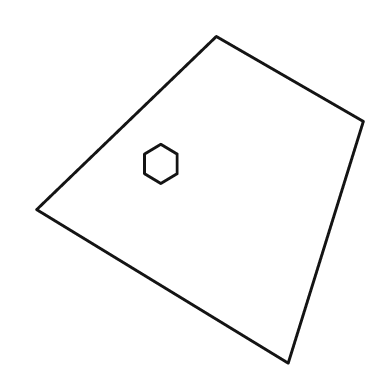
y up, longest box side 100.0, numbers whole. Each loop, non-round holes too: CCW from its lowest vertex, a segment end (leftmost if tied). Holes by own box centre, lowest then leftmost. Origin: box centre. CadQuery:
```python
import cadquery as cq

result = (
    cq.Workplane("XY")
    .moveTo(27.0, -50.0)
    .lineTo(50.0, 24.0)
    .lineTo(5.0, 50.0)
    .lineTo(-50.0, -3.0)
    .close()
    .moveTo(-12.0, 5.0)
    .lineTo(-7.0, 8.0)
    .lineTo(-7.0, 14.0)
    .lineTo(-12.0, 17.0)
    .lineTo(-17.0, 14.0)
    .lineTo(-17.0, 8.0)
    .close()
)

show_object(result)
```